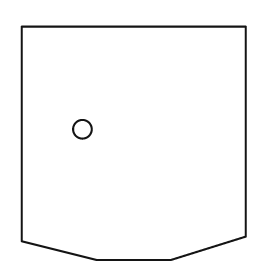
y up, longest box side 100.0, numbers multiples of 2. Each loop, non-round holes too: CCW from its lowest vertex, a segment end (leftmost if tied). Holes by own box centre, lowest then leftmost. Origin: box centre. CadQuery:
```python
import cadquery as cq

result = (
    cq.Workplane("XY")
    .moveTo(-16.0, -50.0)
    .lineTo(16.0, -50.0)
    .lineTo(48.0, -40.0)
    .lineTo(48.0, 50.0)
    .lineTo(-48.0, 50.0)
    .lineTo(-48.0, -42.0)
    .close()
    .moveTo(-22.0, 6.0)
    .circle(4.0)
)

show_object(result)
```